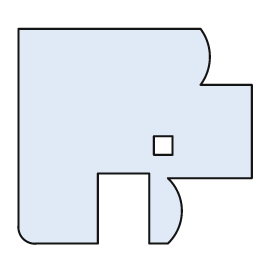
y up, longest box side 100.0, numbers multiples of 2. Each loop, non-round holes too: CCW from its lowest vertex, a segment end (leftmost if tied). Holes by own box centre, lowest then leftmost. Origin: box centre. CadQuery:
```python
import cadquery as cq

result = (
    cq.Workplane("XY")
    .moveTo(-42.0, -46.0)
    .lineTo(-16.0, -46.0)
    .lineTo(-16.0, -16.0)
    .lineTo(6.0, -16.0)
    .lineTo(6.0, -46.0)
    .lineTo(14.0, -46.0)
    .threePointArc((20.0, -32.0), (14.0, -18.0))
    .lineTo(50.0, -18.0)
    .lineTo(50.0, 22.0)
    .lineTo(28.0, 22.0)
    .threePointArc((32.0, 34.0), (28.0, 46.0))
    .lineTo(-50.0, 46.0)
    .lineTo(-50.0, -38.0)
    .threePointArc((-48.0, -44.0), (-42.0, -46.0))
    .close()
    .moveTo(8.0, -8.0)
    .lineTo(16.0, -8.0)
    .lineTo(16.0, 0.0)
    .lineTo(8.0, 0.0)
    .close()
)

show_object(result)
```